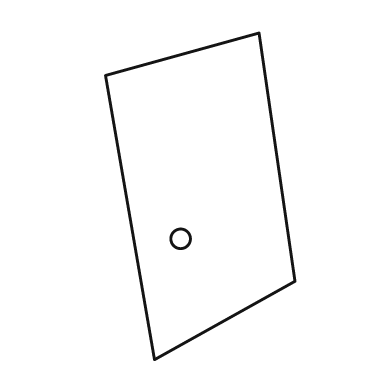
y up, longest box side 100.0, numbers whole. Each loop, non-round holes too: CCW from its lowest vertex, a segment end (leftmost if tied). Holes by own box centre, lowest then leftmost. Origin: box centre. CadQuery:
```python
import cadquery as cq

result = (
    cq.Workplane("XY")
    .moveTo(-14.0, -50.0)
    .lineTo(29.0, -26.0)
    .lineTo(18.0, 50.0)
    .lineTo(-29.0, 37.0)
    .close()
    .moveTo(-6.0, -13.0)
    .circle(3.0)
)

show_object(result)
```